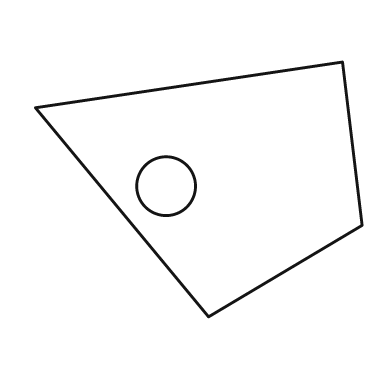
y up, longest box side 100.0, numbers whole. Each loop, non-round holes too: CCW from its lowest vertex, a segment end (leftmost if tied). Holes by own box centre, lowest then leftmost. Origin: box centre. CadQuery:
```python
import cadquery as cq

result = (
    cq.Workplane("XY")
    .moveTo(3.0, -39.0)
    .lineTo(50.0, -11.0)
    .lineTo(44.0, 39.0)
    .lineTo(-50.0, 25.0)
    .close()
    .moveTo(-10.0, 1.0)
    .circle(9.0)
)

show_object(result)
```